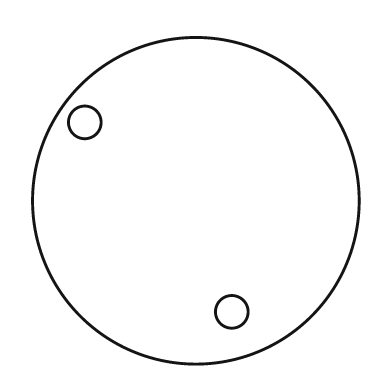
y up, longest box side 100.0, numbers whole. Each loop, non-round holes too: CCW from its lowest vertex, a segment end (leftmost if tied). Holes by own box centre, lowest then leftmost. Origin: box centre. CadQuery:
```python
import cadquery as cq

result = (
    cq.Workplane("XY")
    .moveTo(0.0, 0.0)
    .circle(50.0)
    .moveTo(11.0, -34.0)
    .circle(5.0)
    .moveTo(-34.0, 24.0)
    .circle(5.0)
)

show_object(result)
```